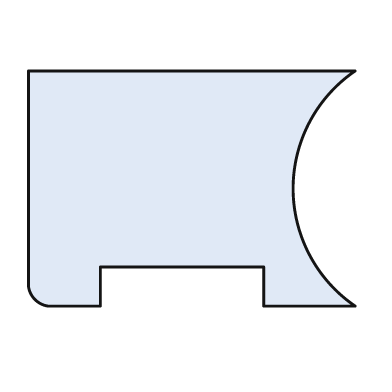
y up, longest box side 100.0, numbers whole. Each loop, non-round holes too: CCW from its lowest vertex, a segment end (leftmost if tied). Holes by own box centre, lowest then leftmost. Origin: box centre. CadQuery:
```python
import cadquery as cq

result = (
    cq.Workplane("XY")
    .moveTo(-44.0, -36.0)
    .lineTo(-28.0, -36.0)
    .lineTo(-28.0, -24.0)
    .lineTo(22.0, -24.0)
    .lineTo(22.0, -36.0)
    .lineTo(50.0, -36.0)
    .threePointArc((31.0, 0.0), (50.0, 36.0))
    .lineTo(-50.0, 36.0)
    .lineTo(-50.0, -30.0)
    .threePointArc((-48.0, -34.0), (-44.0, -36.0))
    .close()
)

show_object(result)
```